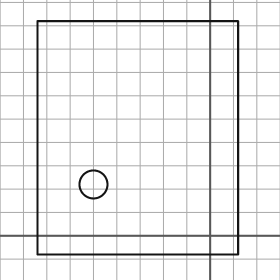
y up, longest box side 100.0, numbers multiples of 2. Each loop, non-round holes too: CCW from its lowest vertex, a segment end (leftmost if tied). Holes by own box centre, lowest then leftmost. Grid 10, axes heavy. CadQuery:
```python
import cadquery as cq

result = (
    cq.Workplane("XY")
    .moveTo(-74.0, -8.0)
    .lineTo(12.0, -8.0)
    .lineTo(12.0, 92.0)
    .lineTo(-74.0, 92.0)
    .close()
    .moveTo(-50.0, 22.0)
    .circle(6.0)
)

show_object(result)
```